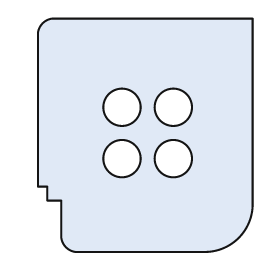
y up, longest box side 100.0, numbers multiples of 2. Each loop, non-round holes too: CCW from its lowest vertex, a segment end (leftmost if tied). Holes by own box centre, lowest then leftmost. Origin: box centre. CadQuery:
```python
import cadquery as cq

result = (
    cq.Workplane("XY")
    .moveTo(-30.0, -50.0)
    .lineTo(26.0, -50.0)
    .threePointArc((40.0, -44.0), (46.0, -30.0))
    .lineTo(46.0, 50.0)
    .lineTo(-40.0, 50.0)
    .threePointArc((-44.0, 48.0), (-46.0, 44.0))
    .lineTo(-46.0, -22.0)
    .lineTo(-42.0, -22.0)
    .lineTo(-42.0, -28.0)
    .lineTo(-36.0, -28.0)
    .lineTo(-36.0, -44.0)
    .threePointArc((-34.0, -48.0), (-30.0, -50.0))
    .close()
    .moveTo(-10.0, -10.0)
    .circle(8.0)
    .moveTo(12.0, -10.0)
    .circle(8.0)
    .moveTo(-10.0, 12.0)
    .circle(8.0)
    .moveTo(12.0, 12.0)
    .circle(8.0)
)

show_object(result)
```